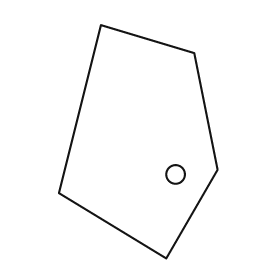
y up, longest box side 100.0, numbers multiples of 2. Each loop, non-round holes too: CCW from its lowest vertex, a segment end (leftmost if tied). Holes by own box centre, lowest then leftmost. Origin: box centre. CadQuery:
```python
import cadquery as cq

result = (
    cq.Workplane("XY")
    .moveTo(12.0, -50.0)
    .lineTo(34.0, -12.0)
    .lineTo(24.0, 38.0)
    .lineTo(-16.0, 50.0)
    .lineTo(-34.0, -22.0)
    .close()
    .moveTo(16.0, -14.0)
    .circle(4.0)
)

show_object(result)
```